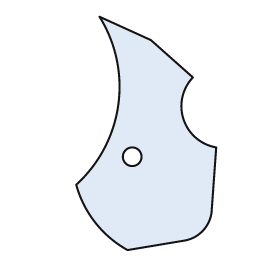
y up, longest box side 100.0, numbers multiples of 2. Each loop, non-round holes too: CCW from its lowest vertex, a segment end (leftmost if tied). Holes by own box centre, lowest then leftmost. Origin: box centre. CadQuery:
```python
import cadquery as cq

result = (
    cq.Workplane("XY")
    .moveTo(-8.0, -50.0)
    .lineTo(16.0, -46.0)
    .threePointArc((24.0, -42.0), (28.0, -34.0))
    .lineTo(30.0, -6.0)
    .threePointArc((16.0, 6.0), (20.0, 24.0))
    .lineTo(2.0, 40.0)
    .lineTo(-20.0, 50.0)
    .threePointArc((-12.0, 12.0), (-30.0, -22.0))
    .threePointArc((-22.0, -38.0), (-8.0, -50.0))
    .close()
    .moveTo(-6.0, -10.0)
    .circle(4.0)
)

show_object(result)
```